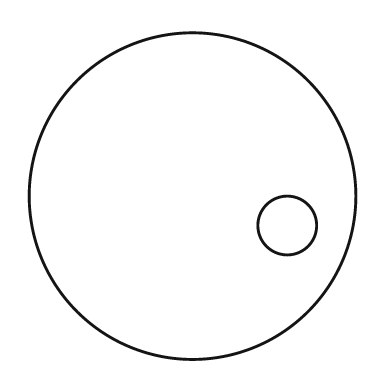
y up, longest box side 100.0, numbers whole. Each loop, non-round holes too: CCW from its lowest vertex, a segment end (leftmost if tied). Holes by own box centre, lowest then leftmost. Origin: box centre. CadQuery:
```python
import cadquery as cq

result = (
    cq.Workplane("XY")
    .moveTo(0.0, 0.0)
    .circle(50.0)
    .moveTo(29.0, -9.0)
    .circle(9.0)
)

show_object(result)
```